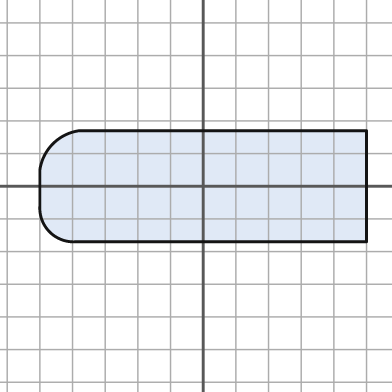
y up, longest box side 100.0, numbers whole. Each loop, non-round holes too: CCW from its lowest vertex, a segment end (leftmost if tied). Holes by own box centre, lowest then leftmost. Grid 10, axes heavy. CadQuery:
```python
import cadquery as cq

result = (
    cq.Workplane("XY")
    .moveTo(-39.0, -17.0)
    .lineTo(50.0, -17.0)
    .lineTo(50.0, 17.0)
    .lineTo(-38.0, 17.0)
    .threePointArc((-46.0, 13.0), (-50.0, 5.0))
    .lineTo(-50.0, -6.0)
    .threePointArc((-47.0, -14.0), (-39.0, -17.0))
    .close()
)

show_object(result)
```